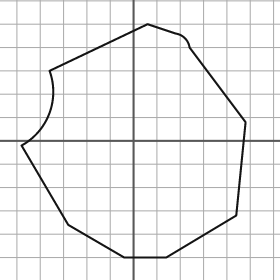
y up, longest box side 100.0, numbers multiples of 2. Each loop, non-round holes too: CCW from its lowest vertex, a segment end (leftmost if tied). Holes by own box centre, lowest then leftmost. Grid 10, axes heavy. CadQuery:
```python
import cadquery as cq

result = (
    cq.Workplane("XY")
    .moveTo(-4.0, -50.0)
    .lineTo(14.0, -50.0)
    .lineTo(44.0, -32.0)
    .lineTo(48.0, 8.0)
    .lineTo(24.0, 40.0)
    .threePointArc((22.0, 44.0), (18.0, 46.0))
    .lineTo(6.0, 50.0)
    .lineTo(-36.0, 30.0)
    .threePointArc((-36.0, 12.0), (-48.0, -2.0))
    .lineTo(-28.0, -36.0)
    .close()
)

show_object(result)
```